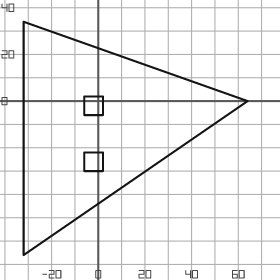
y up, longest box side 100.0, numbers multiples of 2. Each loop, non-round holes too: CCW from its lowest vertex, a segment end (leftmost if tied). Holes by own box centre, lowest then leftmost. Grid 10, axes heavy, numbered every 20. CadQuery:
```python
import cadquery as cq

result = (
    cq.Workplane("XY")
    .moveTo(-32.0, -66.0)
    .lineTo(64.0, 0.0)
    .lineTo(-32.0, 34.0)
    .close()
    .moveTo(-6.0, -30.0)
    .lineTo(2.0, -30.0)
    .lineTo(2.0, -22.0)
    .lineTo(-6.0, -22.0)
    .close()
    .moveTo(-6.0, -6.0)
    .lineTo(2.0, -6.0)
    .lineTo(2.0, 2.0)
    .lineTo(-6.0, 2.0)
    .close()
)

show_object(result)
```